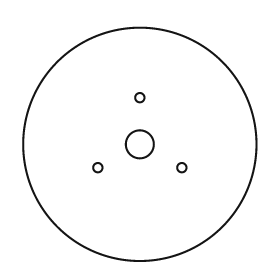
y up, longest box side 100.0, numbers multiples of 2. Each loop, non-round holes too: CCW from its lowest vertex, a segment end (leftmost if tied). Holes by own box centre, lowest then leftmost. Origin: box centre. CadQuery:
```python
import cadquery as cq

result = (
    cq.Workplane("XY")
    .moveTo(0.0, 0.0)
    .circle(50.0)
    .moveTo(-18.0, -10.0)
    .circle(2.0)
    .moveTo(18.0, -10.0)
    .circle(2.0)
    .moveTo(0.0, 0.0)
    .circle(6.0)
    .moveTo(0.0, 20.0)
    .circle(2.0)
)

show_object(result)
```